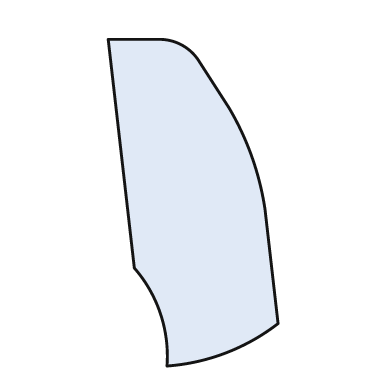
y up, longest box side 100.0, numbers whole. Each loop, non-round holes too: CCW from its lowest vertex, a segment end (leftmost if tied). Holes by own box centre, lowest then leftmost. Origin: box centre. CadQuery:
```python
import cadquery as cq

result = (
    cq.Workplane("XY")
    .moveTo(-8.0, -50.0)
    .threePointArc((10.0, -46.0), (26.0, -37.0))
    .lineTo(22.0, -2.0)
    .threePointArc((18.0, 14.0), (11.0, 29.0))
    .lineTo(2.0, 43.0)
    .threePointArc((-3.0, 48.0), (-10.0, 50.0))
    .lineTo(-26.0, 50.0)
    .lineTo(-18.0, -20.0)
    .threePointArc((-10.0, -34.0), (-8.0, -50.0))
    .close()
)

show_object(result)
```